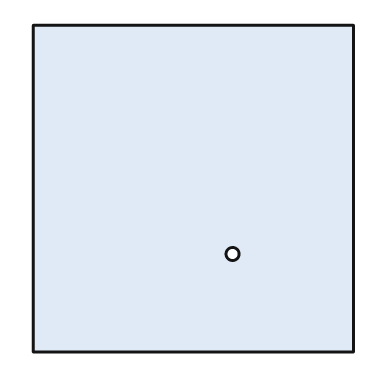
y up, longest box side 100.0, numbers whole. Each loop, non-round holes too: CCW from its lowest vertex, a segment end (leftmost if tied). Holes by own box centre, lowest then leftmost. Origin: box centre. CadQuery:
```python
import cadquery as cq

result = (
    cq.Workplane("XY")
    .moveTo(-49.0, -50.0)
    .lineTo(49.0, -50.0)
    .lineTo(49.0, 50.0)
    .lineTo(-49.0, 50.0)
    .close()
    .moveTo(12.0, -20.0)
    .circle(2.0)
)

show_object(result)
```